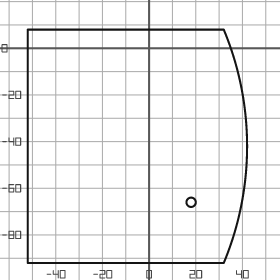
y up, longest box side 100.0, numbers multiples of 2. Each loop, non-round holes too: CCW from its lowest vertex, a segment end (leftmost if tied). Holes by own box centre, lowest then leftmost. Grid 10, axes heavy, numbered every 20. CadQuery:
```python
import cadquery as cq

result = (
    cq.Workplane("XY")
    .moveTo(-52.0, -92.0)
    .lineTo(32.0, -92.0)
    .threePointArc((42.0, -42.0), (32.0, 8.0))
    .lineTo(-52.0, 8.0)
    .close()
    .moveTo(18.0, -66.0)
    .circle(2.0)
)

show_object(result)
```